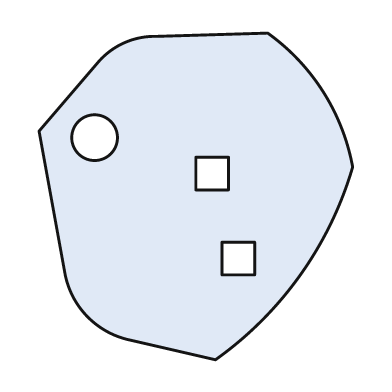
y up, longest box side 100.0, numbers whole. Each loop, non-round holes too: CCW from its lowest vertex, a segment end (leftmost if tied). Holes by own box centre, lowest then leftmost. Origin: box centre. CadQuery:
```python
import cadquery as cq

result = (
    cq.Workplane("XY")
    .moveTo(6.0, -50.0)
    .threePointArc((32.0, -24.0), (48.0, 9.0))
    .threePointArc((39.0, 32.0), (22.0, 50.0))
    .lineTo(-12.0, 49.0)
    .threePointArc((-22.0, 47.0), (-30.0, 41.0))
    .lineTo(-48.0, 20.0)
    .lineTo(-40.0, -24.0)
    .threePointArc((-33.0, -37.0), (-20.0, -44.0))
    .close()
    .moveTo(8.0, -24.0)
    .lineTo(18.0, -24.0)
    .lineTo(18.0, -14.0)
    .lineTo(8.0, -14.0)
    .close()
    .moveTo(0.0, 2.0)
    .lineTo(10.0, 2.0)
    .lineTo(10.0, 12.0)
    .lineTo(0.0, 12.0)
    .close()
    .moveTo(-31.0, 18.0)
    .circle(7.0)
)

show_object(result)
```